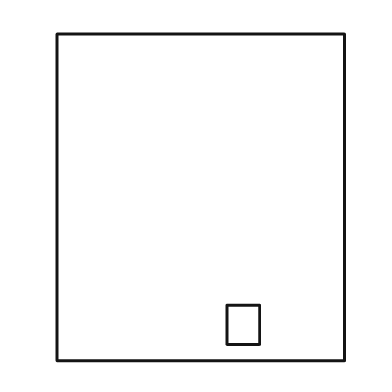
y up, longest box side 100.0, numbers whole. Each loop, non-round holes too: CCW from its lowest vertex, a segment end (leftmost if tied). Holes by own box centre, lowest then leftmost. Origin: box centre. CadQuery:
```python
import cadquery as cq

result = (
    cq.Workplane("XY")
    .moveTo(-44.0, -50.0)
    .lineTo(44.0, -50.0)
    .lineTo(44.0, 50.0)
    .lineTo(-44.0, 50.0)
    .close()
    .moveTo(8.0, -45.0)
    .lineTo(18.0, -45.0)
    .lineTo(18.0, -33.0)
    .lineTo(8.0, -33.0)
    .close()
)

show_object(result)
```